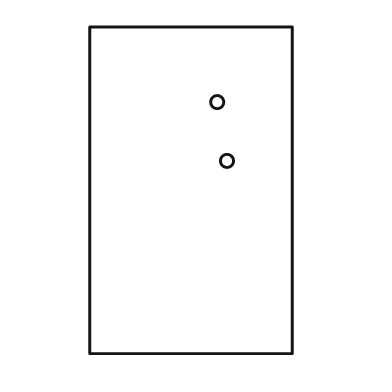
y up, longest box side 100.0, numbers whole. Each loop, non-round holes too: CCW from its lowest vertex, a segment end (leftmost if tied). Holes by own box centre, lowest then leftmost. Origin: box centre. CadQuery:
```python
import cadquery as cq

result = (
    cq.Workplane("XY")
    .moveTo(-31.0, -50.0)
    .lineTo(31.0, -50.0)
    .lineTo(31.0, 50.0)
    .lineTo(-31.0, 50.0)
    .close()
    .moveTo(11.0, 9.0)
    .circle(2.0)
    .moveTo(8.0, 27.0)
    .circle(2.0)
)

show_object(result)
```